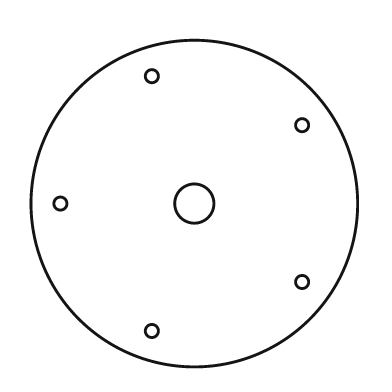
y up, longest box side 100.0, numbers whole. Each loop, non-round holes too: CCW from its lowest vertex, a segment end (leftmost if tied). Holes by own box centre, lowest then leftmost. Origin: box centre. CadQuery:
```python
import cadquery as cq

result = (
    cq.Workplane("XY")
    .moveTo(0.0, 0.0)
    .circle(50.0)
    .moveTo(-13.0, -39.0)
    .circle(2.0)
    .moveTo(33.0, -24.0)
    .circle(2.0)
    .moveTo(-41.0, 0.0)
    .circle(2.0)
    .moveTo(0.0, 0.0)
    .circle(6.0)
    .moveTo(33.0, 24.0)
    .circle(2.0)
    .moveTo(-13.0, 39.0)
    .circle(2.0)
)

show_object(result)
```